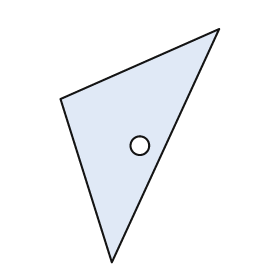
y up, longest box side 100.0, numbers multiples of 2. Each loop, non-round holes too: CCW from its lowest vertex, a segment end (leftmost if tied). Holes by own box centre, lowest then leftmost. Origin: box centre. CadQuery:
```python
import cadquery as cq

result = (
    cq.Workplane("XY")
    .moveTo(-12.0, -50.0)
    .lineTo(34.0, 50.0)
    .lineTo(-34.0, 20.0)
    .close()
    .moveTo(0.0, 0.0)
    .circle(4.0)
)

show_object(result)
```